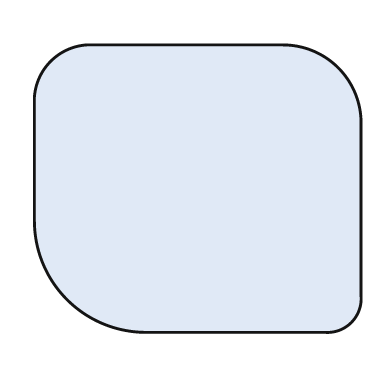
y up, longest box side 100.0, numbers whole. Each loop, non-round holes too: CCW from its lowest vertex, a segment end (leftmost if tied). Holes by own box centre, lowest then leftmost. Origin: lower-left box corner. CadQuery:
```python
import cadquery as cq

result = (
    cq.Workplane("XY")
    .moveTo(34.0, 0.0)
    .lineTo(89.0, 0.0)
    .threePointArc((97.0, 3.0), (100.0, 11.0))
    .lineTo(100.0, 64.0)
    .threePointArc((93.0, 81.0), (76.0, 88.0))
    .lineTo(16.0, 88.0)
    .threePointArc((5.0, 83.0), (0.0, 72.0))
    .lineTo(0.0, 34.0)
    .threePointArc((10.0, 10.0), (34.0, 0.0))
    .close()
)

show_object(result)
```